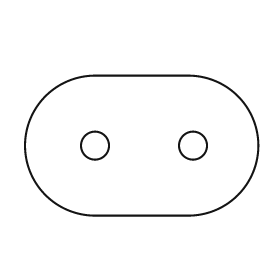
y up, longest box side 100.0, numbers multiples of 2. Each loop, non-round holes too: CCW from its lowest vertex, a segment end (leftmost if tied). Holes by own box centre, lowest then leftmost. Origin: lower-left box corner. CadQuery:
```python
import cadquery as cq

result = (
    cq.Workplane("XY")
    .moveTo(30.0, 0.0)
    .lineTo(70.0, 0.0)
    .threePointArc((100.0, 30.0), (70.0, 60.0))
    .lineTo(30.0, 60.0)
    .threePointArc((0.0, 30.0), (30.0, 0.0))
    .close()
    .moveTo(30.0, 30.0)
    .circle(6.0)
    .moveTo(72.0, 30.0)
    .circle(6.0)
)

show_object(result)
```